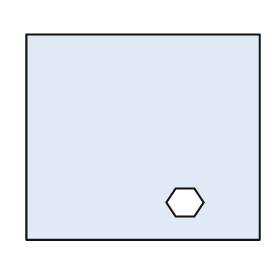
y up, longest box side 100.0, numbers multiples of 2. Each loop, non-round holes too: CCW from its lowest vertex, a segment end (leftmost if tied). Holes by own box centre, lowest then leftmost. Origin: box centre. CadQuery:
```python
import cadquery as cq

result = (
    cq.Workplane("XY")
    .moveTo(-50.0, -44.0)
    .lineTo(50.0, -44.0)
    .lineTo(50.0, 44.0)
    .lineTo(-50.0, 44.0)
    .close()
    .moveTo(14.0, -34.0)
    .lineTo(22.0, -34.0)
    .lineTo(26.0, -28.0)
    .lineTo(22.0, -22.0)
    .lineTo(14.0, -22.0)
    .lineTo(10.0, -28.0)
    .close()
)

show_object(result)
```